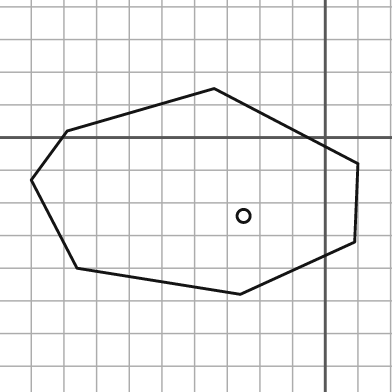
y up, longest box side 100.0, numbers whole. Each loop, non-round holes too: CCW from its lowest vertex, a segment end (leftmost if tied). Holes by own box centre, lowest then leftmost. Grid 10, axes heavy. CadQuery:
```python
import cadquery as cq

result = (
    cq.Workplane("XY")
    .moveTo(-26.0, -48.0)
    .lineTo(9.0, -32.0)
    .lineTo(10.0, -8.0)
    .lineTo(-34.0, 15.0)
    .lineTo(-79.0, 2.0)
    .lineTo(-90.0, -13.0)
    .lineTo(-76.0, -40.0)
    .close()
    .moveTo(-25.0, -24.0)
    .circle(2.0)
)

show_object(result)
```